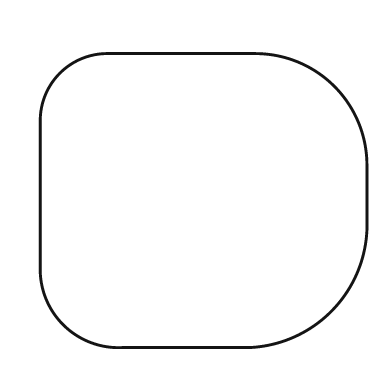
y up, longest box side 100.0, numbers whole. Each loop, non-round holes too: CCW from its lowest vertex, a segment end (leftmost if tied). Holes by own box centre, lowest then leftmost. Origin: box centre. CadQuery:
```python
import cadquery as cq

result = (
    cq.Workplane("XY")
    .moveTo(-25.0, -45.0)
    .lineTo(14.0, -45.0)
    .threePointArc((39.0, -34.0), (50.0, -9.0))
    .lineTo(50.0, 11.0)
    .threePointArc((40.0, 35.0), (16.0, 45.0))
    .lineTo(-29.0, 45.0)
    .threePointArc((-44.0, 39.0), (-50.0, 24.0))
    .lineTo(-50.0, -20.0)
    .threePointArc((-43.0, -38.0), (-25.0, -45.0))
    .close()
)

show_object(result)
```